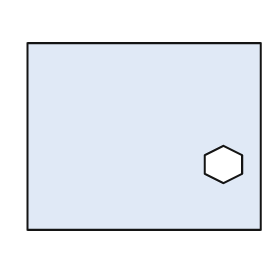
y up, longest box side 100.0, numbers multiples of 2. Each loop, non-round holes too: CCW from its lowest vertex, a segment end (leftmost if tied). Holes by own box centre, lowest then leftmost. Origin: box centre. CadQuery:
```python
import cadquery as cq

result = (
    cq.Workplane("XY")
    .moveTo(-50.0, -40.0)
    .lineTo(50.0, -40.0)
    .lineTo(50.0, 40.0)
    .lineTo(-50.0, 40.0)
    .close()
    .moveTo(34.0, -20.0)
    .lineTo(42.0, -16.0)
    .lineTo(42.0, -8.0)
    .lineTo(34.0, -4.0)
    .lineTo(26.0, -8.0)
    .lineTo(26.0, -16.0)
    .close()
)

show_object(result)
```